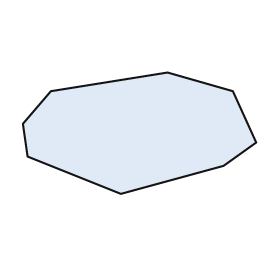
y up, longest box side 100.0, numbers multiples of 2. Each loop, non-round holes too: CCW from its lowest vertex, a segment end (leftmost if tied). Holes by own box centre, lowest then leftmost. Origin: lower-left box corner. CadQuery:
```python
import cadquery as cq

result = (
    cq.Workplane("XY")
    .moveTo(42.0, 0.0)
    .lineTo(86.0, 12.0)
    .lineTo(100.0, 22.0)
    .lineTo(90.0, 44.0)
    .lineTo(62.0, 52.0)
    .lineTo(12.0, 44.0)
    .lineTo(0.0, 30.0)
    .lineTo(2.0, 16.0)
    .close()
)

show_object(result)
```